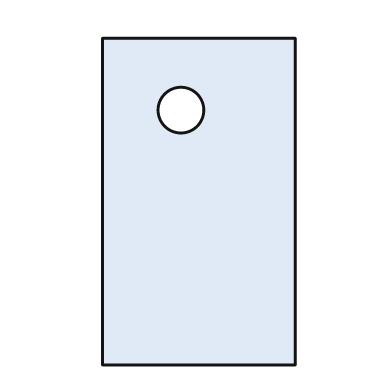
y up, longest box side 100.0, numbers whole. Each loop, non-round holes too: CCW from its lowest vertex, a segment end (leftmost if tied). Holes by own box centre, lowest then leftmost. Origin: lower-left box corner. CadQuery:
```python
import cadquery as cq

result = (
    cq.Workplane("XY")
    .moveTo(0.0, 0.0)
    .lineTo(59.0, 0.0)
    .lineTo(59.0, 100.0)
    .lineTo(0.0, 100.0)
    .close()
    .moveTo(24.0, 78.0)
    .circle(7.0)
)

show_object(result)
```